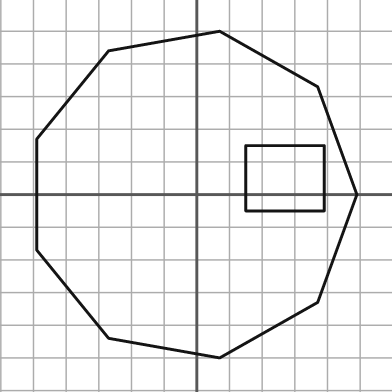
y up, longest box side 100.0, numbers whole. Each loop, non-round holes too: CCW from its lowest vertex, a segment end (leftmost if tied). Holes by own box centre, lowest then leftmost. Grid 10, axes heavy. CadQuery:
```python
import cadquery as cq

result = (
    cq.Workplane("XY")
    .moveTo(7.0, -50.0)
    .lineTo(37.0, -33.0)
    .lineTo(49.0, 0.0)
    .lineTo(37.0, 33.0)
    .lineTo(7.0, 50.0)
    .lineTo(-27.0, 44.0)
    .lineTo(-49.0, 17.0)
    .lineTo(-49.0, -17.0)
    .lineTo(-27.0, -44.0)
    .close()
    .moveTo(15.0, -5.0)
    .lineTo(39.0, -5.0)
    .lineTo(39.0, 15.0)
    .lineTo(15.0, 15.0)
    .close()
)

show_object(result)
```